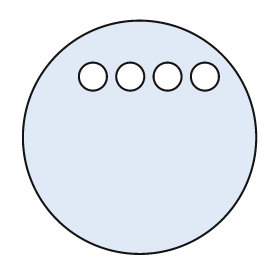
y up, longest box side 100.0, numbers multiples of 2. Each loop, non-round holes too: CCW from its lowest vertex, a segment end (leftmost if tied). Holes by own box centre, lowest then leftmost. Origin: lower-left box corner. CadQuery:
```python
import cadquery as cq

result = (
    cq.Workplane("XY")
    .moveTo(50.0, 50.0)
    .circle(50.0)
    .moveTo(30.0, 76.0)
    .circle(6.0)
    .moveTo(46.0, 76.0)
    .circle(6.0)
    .moveTo(62.0, 76.0)
    .circle(6.0)
    .moveTo(78.0, 76.0)
    .circle(6.0)
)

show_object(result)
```